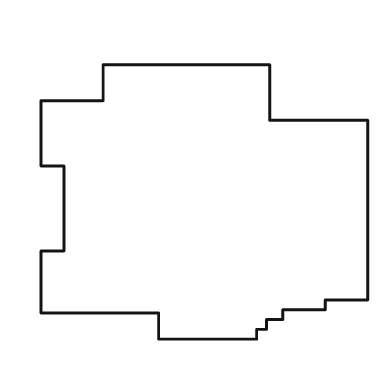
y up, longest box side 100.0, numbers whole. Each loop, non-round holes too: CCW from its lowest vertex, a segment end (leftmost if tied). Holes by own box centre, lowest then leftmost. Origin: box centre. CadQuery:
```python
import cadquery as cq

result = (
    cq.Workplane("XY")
    .moveTo(-14.0, -42.0)
    .lineTo(16.0, -42.0)
    .lineTo(16.0, -39.0)
    .lineTo(19.0, -39.0)
    .lineTo(19.0, -36.0)
    .lineTo(24.0, -36.0)
    .lineTo(24.0, -33.0)
    .lineTo(37.0, -33.0)
    .lineTo(37.0, -30.0)
    .lineTo(50.0, -30.0)
    .lineTo(50.0, 25.0)
    .lineTo(20.0, 25.0)
    .lineTo(20.0, 42.0)
    .lineTo(-31.0, 42.0)
    .lineTo(-31.0, 31.0)
    .lineTo(-50.0, 31.0)
    .lineTo(-50.0, 11.0)
    .lineTo(-43.0, 11.0)
    .lineTo(-43.0, -15.0)
    .lineTo(-50.0, -15.0)
    .lineTo(-50.0, -34.0)
    .lineTo(-14.0, -34.0)
    .close()
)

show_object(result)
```